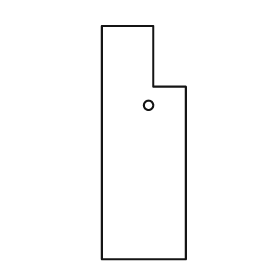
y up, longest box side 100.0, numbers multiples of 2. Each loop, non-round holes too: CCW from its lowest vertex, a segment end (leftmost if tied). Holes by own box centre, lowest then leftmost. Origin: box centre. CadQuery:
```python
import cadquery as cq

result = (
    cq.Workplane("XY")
    .moveTo(-18.0, -50.0)
    .lineTo(18.0, -50.0)
    .lineTo(18.0, 24.0)
    .lineTo(4.0, 24.0)
    .lineTo(4.0, 50.0)
    .lineTo(-18.0, 50.0)
    .close()
    .moveTo(2.0, 16.0)
    .circle(2.0)
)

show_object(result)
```